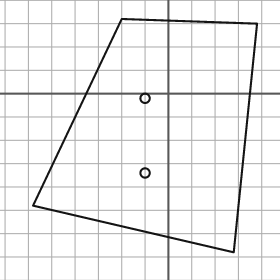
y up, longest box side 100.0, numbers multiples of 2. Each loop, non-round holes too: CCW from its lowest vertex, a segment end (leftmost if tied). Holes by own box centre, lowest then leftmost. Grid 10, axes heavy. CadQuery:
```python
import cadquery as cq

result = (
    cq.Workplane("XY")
    .moveTo(28.0, -68.0)
    .lineTo(38.0, 30.0)
    .lineTo(-20.0, 32.0)
    .lineTo(-58.0, -48.0)
    .close()
    .moveTo(-10.0, -34.0)
    .circle(2.0)
    .moveTo(-10.0, -2.0)
    .circle(2.0)
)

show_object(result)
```